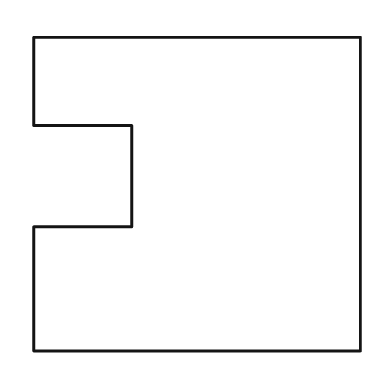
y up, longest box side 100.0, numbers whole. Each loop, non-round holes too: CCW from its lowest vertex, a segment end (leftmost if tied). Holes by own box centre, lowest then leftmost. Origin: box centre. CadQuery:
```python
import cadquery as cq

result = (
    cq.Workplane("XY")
    .moveTo(-50.0, -48.0)
    .lineTo(50.0, -48.0)
    .lineTo(50.0, 48.0)
    .lineTo(-50.0, 48.0)
    .lineTo(-50.0, 21.0)
    .lineTo(-20.0, 21.0)
    .lineTo(-20.0, -10.0)
    .lineTo(-50.0, -10.0)
    .close()
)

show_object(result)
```